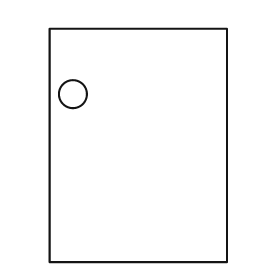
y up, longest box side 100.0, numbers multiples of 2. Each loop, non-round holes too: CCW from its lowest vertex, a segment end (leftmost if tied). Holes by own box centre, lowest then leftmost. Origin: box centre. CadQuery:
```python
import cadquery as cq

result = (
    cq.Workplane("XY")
    .moveTo(-38.0, -50.0)
    .lineTo(38.0, -50.0)
    .lineTo(38.0, 50.0)
    .lineTo(-38.0, 50.0)
    .close()
    .moveTo(-28.0, 22.0)
    .circle(6.0)
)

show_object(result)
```